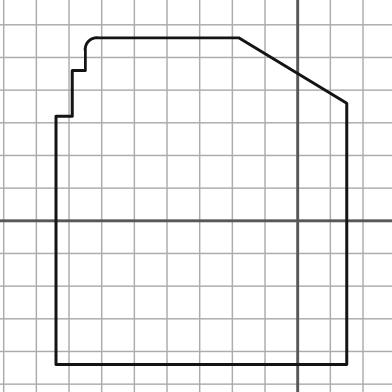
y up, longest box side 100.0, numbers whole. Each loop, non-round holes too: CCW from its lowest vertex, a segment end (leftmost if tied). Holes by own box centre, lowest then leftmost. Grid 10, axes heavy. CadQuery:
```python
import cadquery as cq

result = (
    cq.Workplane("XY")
    .moveTo(-74.0, -44.0)
    .lineTo(15.0, -44.0)
    .lineTo(15.0, 36.0)
    .lineTo(-18.0, 56.0)
    .lineTo(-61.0, 56.0)
    .threePointArc((-64.0, 55.0), (-65.0, 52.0))
    .lineTo(-65.0, 46.0)
    .lineTo(-69.0, 46.0)
    .lineTo(-69.0, 32.0)
    .lineTo(-74.0, 32.0)
    .close()
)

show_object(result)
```